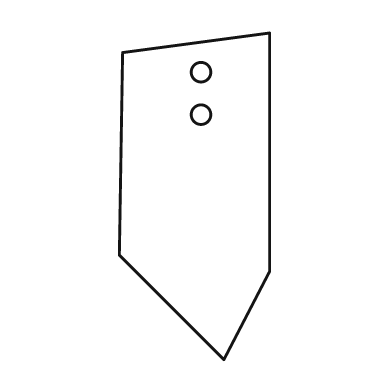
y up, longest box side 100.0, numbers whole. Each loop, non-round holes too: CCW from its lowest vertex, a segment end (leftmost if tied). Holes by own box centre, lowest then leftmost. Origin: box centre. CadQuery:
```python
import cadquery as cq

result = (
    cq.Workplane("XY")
    .moveTo(9.0, -50.0)
    .lineTo(23.0, -23.0)
    .lineTo(23.0, 50.0)
    .lineTo(-22.0, 44.0)
    .lineTo(-23.0, -18.0)
    .close()
    .moveTo(2.0, 25.0)
    .circle(3.0)
    .moveTo(2.0, 38.0)
    .circle(3.0)
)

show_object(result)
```